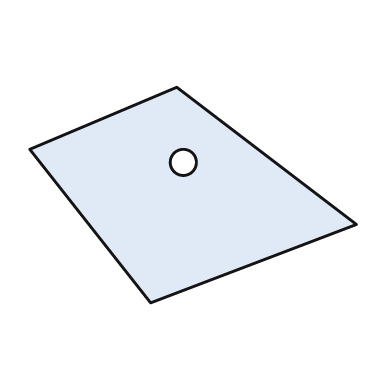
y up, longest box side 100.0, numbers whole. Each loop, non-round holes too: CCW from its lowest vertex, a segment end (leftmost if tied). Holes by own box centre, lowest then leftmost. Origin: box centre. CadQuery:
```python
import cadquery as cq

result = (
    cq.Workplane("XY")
    .moveTo(-13.0, -33.0)
    .lineTo(50.0, -9.0)
    .lineTo(-5.0, 33.0)
    .lineTo(-50.0, 14.0)
    .close()
    .moveTo(-3.0, 10.0)
    .circle(4.0)
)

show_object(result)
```